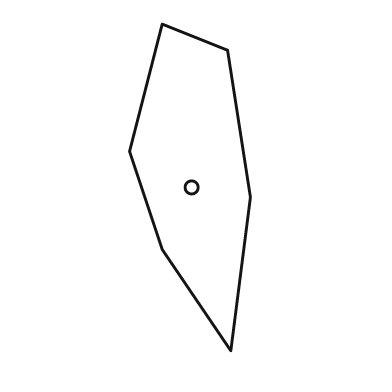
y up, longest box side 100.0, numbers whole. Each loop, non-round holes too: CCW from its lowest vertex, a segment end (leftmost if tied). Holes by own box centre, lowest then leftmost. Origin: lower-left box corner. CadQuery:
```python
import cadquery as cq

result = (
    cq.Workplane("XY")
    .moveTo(31.0, 0.0)
    .lineTo(37.0, 47.0)
    .lineTo(30.0, 92.0)
    .lineTo(10.0, 100.0)
    .lineTo(0.0, 61.0)
    .lineTo(10.0, 31.0)
    .close()
    .moveTo(19.0, 50.0)
    .circle(2.0)
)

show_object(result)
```